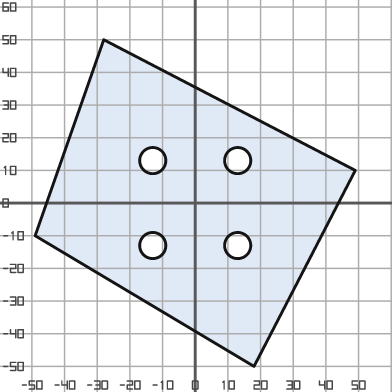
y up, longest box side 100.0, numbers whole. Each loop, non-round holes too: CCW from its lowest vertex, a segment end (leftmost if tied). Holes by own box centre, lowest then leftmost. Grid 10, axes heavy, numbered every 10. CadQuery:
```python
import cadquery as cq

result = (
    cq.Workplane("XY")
    .moveTo(18.0, -50.0)
    .lineTo(49.0, 10.0)
    .lineTo(-28.0, 50.0)
    .lineTo(-49.0, -10.0)
    .close()
    .moveTo(-13.0, -13.0)
    .circle(4.0)
    .moveTo(13.0, -13.0)
    .circle(4.0)
    .moveTo(-13.0, 13.0)
    .circle(4.0)
    .moveTo(13.0, 13.0)
    .circle(4.0)
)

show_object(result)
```